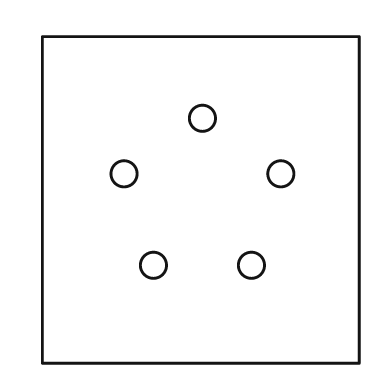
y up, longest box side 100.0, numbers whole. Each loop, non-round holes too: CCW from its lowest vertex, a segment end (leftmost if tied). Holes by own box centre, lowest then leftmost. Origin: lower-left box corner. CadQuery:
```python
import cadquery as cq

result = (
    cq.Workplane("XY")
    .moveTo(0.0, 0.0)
    .lineTo(97.0, 0.0)
    .lineTo(97.0, 100.0)
    .lineTo(0.0, 100.0)
    .close()
    .moveTo(34.0, 30.0)
    .circle(4.0)
    .moveTo(64.0, 30.0)
    .circle(4.0)
    .moveTo(25.0, 58.0)
    .circle(4.0)
    .moveTo(73.0, 58.0)
    .circle(4.0)
    .moveTo(49.0, 75.0)
    .circle(4.0)
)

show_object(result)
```